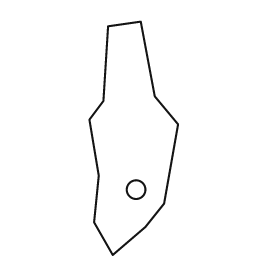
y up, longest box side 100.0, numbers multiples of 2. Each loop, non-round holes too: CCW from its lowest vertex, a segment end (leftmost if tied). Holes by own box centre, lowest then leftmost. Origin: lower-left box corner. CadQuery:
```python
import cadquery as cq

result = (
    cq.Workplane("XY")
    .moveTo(10.0, 0.0)
    .lineTo(24.0, 12.0)
    .lineTo(32.0, 22.0)
    .lineTo(38.0, 56.0)
    .lineTo(28.0, 68.0)
    .lineTo(22.0, 100.0)
    .lineTo(8.0, 98.0)
    .lineTo(6.0, 66.0)
    .lineTo(0.0, 58.0)
    .lineTo(4.0, 34.0)
    .lineTo(2.0, 14.0)
    .close()
    .moveTo(20.0, 28.0)
    .circle(4.0)
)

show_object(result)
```